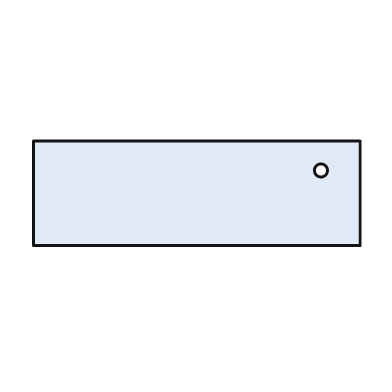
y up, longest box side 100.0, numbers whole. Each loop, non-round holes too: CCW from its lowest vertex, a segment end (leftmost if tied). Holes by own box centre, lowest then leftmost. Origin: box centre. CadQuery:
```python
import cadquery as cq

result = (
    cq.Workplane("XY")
    .moveTo(-50.0, -16.0)
    .lineTo(50.0, -16.0)
    .lineTo(50.0, 16.0)
    .lineTo(-50.0, 16.0)
    .close()
    .moveTo(38.0, 7.0)
    .circle(2.0)
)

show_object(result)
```